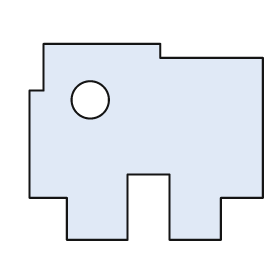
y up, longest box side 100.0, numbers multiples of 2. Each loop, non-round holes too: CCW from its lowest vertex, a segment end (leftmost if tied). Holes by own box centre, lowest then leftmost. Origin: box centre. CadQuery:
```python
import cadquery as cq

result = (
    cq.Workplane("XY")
    .moveTo(-34.0, -42.0)
    .lineTo(-8.0, -42.0)
    .lineTo(-8.0, -14.0)
    .lineTo(10.0, -14.0)
    .lineTo(10.0, -42.0)
    .lineTo(32.0, -42.0)
    .lineTo(32.0, -24.0)
    .lineTo(50.0, -24.0)
    .lineTo(50.0, 36.0)
    .lineTo(6.0, 36.0)
    .lineTo(6.0, 42.0)
    .lineTo(-44.0, 42.0)
    .lineTo(-44.0, 22.0)
    .lineTo(-50.0, 22.0)
    .lineTo(-50.0, -24.0)
    .lineTo(-34.0, -24.0)
    .close()
    .moveTo(-24.0, 18.0)
    .circle(8.0)
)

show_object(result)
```